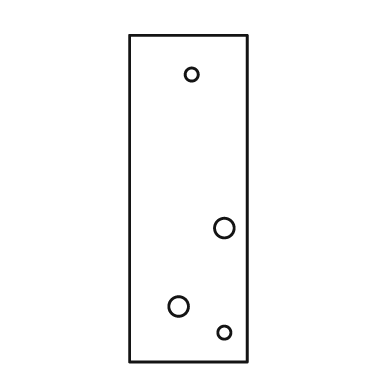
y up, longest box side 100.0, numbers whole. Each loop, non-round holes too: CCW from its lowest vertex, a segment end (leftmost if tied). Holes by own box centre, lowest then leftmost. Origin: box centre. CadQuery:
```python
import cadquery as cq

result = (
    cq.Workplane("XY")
    .moveTo(-18.0, -50.0)
    .lineTo(18.0, -50.0)
    .lineTo(18.0, 50.0)
    .lineTo(-18.0, 50.0)
    .close()
    .moveTo(11.0, -41.0)
    .circle(2.0)
    .moveTo(-3.0, -33.0)
    .circle(3.0)
    .moveTo(11.0, -9.0)
    .circle(3.0)
    .moveTo(1.0, 38.0)
    .circle(2.0)
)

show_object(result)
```